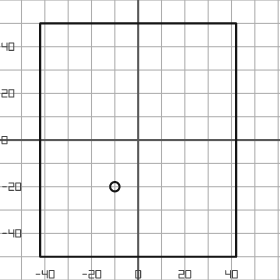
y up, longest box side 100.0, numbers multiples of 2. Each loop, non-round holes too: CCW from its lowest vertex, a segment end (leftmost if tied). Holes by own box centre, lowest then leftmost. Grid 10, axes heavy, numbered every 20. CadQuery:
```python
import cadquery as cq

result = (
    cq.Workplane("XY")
    .moveTo(-42.0, -50.0)
    .lineTo(42.0, -50.0)
    .lineTo(42.0, 50.0)
    .lineTo(-42.0, 50.0)
    .close()
    .moveTo(-10.0, -20.0)
    .circle(2.0)
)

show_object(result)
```